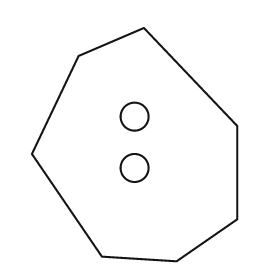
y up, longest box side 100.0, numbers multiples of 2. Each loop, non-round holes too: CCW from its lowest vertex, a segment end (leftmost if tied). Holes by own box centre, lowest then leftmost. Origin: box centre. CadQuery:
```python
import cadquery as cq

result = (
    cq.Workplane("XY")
    .moveTo(18.0, -50.0)
    .lineTo(44.0, -32.0)
    .lineTo(44.0, 8.0)
    .lineTo(4.0, 50.0)
    .lineTo(-24.0, 38.0)
    .lineTo(-44.0, -4.0)
    .lineTo(-14.0, -48.0)
    .close()
    .moveTo(0.0, -10.0)
    .circle(6.0)
    .moveTo(0.0, 12.0)
    .circle(6.0)
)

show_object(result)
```